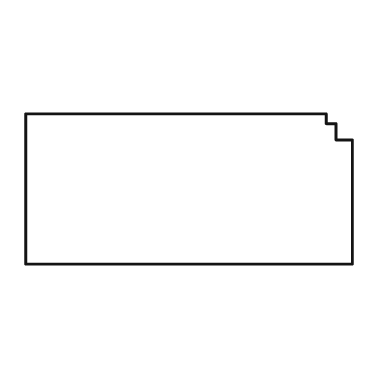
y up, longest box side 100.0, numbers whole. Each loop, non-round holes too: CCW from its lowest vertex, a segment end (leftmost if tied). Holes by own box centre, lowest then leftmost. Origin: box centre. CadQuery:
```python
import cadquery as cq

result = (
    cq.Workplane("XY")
    .moveTo(-50.0, -23.0)
    .lineTo(50.0, -23.0)
    .lineTo(50.0, 15.0)
    .lineTo(45.0, 15.0)
    .lineTo(45.0, 20.0)
    .lineTo(42.0, 20.0)
    .lineTo(42.0, 23.0)
    .lineTo(-50.0, 23.0)
    .close()
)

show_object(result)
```